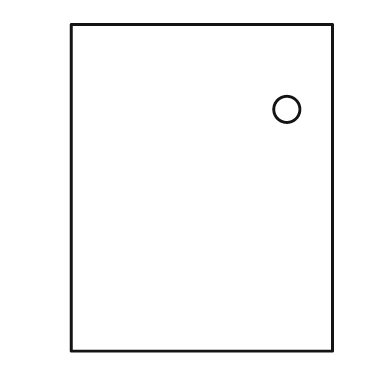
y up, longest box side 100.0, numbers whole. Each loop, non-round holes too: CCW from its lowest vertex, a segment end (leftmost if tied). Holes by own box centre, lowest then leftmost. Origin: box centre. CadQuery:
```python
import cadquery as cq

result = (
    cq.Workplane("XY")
    .moveTo(-40.0, -50.0)
    .lineTo(40.0, -50.0)
    .lineTo(40.0, 50.0)
    .lineTo(-40.0, 50.0)
    .close()
    .moveTo(26.0, 24.0)
    .circle(4.0)
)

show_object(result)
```